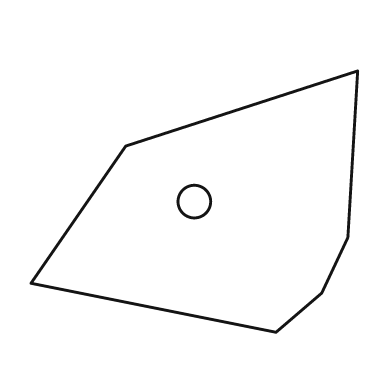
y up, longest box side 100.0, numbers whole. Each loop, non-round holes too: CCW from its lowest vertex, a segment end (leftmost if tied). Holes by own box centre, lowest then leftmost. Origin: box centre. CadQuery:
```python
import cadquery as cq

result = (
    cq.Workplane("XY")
    .moveTo(25.0, -40.0)
    .lineTo(39.0, -28.0)
    .lineTo(47.0, -11.0)
    .lineTo(50.0, 40.0)
    .lineTo(-21.0, 17.0)
    .lineTo(-50.0, -25.0)
    .close()
    .moveTo(0.0, 0.0)
    .circle(5.0)
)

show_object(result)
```